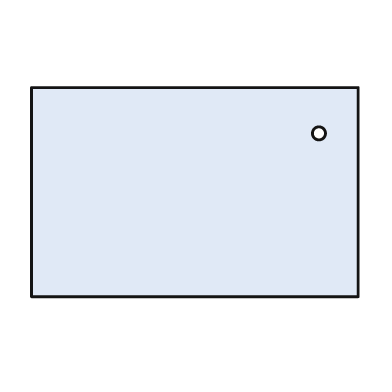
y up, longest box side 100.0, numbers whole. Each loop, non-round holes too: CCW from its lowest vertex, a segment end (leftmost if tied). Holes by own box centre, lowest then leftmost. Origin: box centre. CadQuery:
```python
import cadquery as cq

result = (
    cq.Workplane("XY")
    .moveTo(-50.0, -32.0)
    .lineTo(50.0, -32.0)
    .lineTo(50.0, 32.0)
    .lineTo(-50.0, 32.0)
    .close()
    .moveTo(38.0, 18.0)
    .circle(2.0)
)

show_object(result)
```